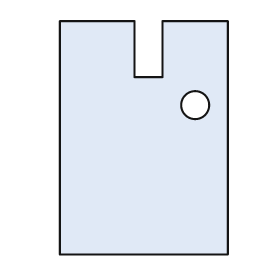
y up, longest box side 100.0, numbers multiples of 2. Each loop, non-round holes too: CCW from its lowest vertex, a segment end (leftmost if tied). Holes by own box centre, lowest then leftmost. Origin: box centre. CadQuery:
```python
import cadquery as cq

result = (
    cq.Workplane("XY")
    .moveTo(-36.0, -50.0)
    .lineTo(36.0, -50.0)
    .lineTo(36.0, 50.0)
    .lineTo(8.0, 50.0)
    .lineTo(8.0, 26.0)
    .lineTo(-4.0, 26.0)
    .lineTo(-4.0, 50.0)
    .lineTo(-36.0, 50.0)
    .close()
    .moveTo(22.0, 14.0)
    .circle(6.0)
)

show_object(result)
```